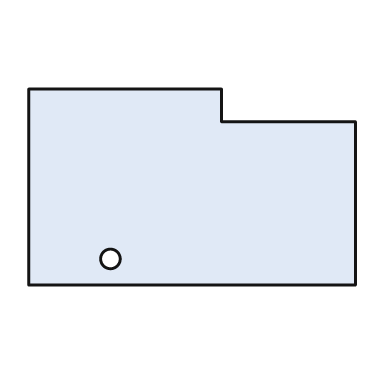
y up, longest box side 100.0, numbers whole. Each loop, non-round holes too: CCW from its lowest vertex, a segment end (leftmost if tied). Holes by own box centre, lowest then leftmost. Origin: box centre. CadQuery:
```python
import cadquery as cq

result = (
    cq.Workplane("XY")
    .moveTo(-50.0, -30.0)
    .lineTo(50.0, -30.0)
    .lineTo(50.0, 20.0)
    .lineTo(9.0, 20.0)
    .lineTo(9.0, 30.0)
    .lineTo(-50.0, 30.0)
    .close()
    .moveTo(-25.0, -22.0)
    .circle(3.0)
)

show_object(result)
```